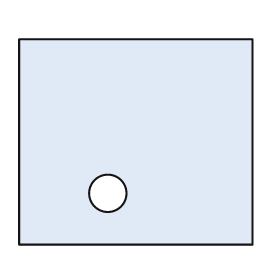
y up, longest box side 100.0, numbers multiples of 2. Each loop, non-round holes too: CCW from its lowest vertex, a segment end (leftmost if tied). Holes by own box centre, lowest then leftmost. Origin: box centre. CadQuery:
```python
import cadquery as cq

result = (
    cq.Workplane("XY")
    .moveTo(-50.0, -44.0)
    .lineTo(50.0, -44.0)
    .lineTo(50.0, 44.0)
    .lineTo(-50.0, 44.0)
    .close()
    .moveTo(-12.0, -22.0)
    .circle(8.0)
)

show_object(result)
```